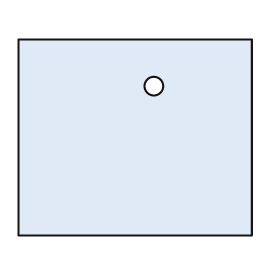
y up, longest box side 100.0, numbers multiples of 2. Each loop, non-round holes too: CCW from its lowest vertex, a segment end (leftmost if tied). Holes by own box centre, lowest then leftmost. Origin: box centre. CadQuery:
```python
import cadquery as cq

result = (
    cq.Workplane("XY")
    .moveTo(-50.0, -42.0)
    .lineTo(50.0, -42.0)
    .lineTo(50.0, 42.0)
    .lineTo(-50.0, 42.0)
    .close()
    .moveTo(8.0, 22.0)
    .circle(4.0)
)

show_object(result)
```